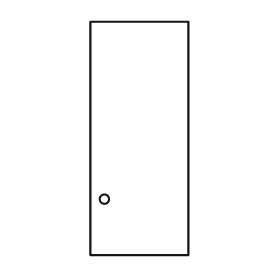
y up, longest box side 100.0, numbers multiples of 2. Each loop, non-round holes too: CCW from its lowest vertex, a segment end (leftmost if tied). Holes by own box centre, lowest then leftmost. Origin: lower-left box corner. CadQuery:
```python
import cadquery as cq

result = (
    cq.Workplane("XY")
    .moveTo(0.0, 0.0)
    .lineTo(42.0, 0.0)
    .lineTo(42.0, 100.0)
    .lineTo(0.0, 100.0)
    .close()
    .moveTo(6.0, 24.0)
    .circle(2.0)
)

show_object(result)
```